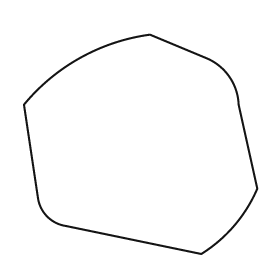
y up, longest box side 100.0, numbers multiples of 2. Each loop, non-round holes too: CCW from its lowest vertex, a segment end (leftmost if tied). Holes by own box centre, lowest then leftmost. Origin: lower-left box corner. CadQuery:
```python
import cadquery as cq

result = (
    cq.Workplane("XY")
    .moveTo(76.0, 0.0)
    .threePointArc((90.0, 12.0), (100.0, 28.0))
    .lineTo(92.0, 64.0)
    .threePointArc((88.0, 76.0), (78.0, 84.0))
    .lineTo(54.0, 94.0)
    .threePointArc((24.0, 84.0), (0.0, 64.0))
    .lineTo(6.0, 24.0)
    .threePointArc((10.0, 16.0), (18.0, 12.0))
    .close()
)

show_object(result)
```